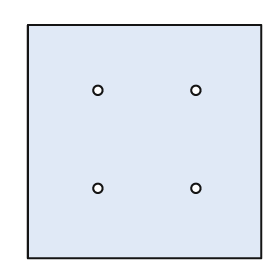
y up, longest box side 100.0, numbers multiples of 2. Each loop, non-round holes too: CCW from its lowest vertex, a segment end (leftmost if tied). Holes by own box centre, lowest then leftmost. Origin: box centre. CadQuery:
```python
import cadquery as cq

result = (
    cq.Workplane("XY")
    .moveTo(-50.0, -50.0)
    .lineTo(50.0, -50.0)
    .lineTo(50.0, 50.0)
    .lineTo(-50.0, 50.0)
    .close()
    .moveTo(-20.0, -20.0)
    .circle(2.0)
    .moveTo(22.0, -20.0)
    .circle(2.0)
    .moveTo(-20.0, 22.0)
    .circle(2.0)
    .moveTo(22.0, 22.0)
    .circle(2.0)
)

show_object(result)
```